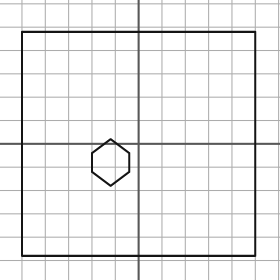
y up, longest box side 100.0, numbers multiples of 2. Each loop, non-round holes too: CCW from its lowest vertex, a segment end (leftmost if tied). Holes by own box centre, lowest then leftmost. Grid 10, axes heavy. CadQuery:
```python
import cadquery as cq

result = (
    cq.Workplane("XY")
    .moveTo(-50.0, -48.0)
    .lineTo(50.0, -48.0)
    .lineTo(50.0, 48.0)
    .lineTo(-50.0, 48.0)
    .close()
    .moveTo(-12.0, -18.0)
    .lineTo(-4.0, -12.0)
    .lineTo(-4.0, -4.0)
    .lineTo(-12.0, 2.0)
    .lineTo(-20.0, -4.0)
    .lineTo(-20.0, -12.0)
    .close()
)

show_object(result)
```